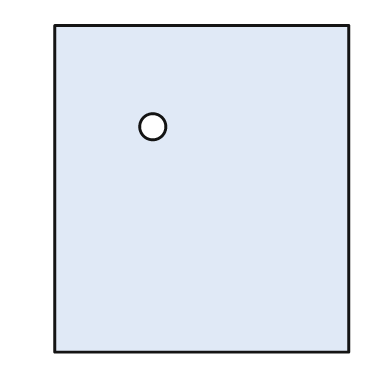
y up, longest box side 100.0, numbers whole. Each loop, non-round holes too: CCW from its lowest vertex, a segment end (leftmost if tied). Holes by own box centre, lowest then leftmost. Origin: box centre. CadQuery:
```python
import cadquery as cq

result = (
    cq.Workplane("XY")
    .moveTo(-45.0, -50.0)
    .lineTo(45.0, -50.0)
    .lineTo(45.0, 50.0)
    .lineTo(-45.0, 50.0)
    .close()
    .moveTo(-15.0, 19.0)
    .circle(4.0)
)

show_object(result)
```